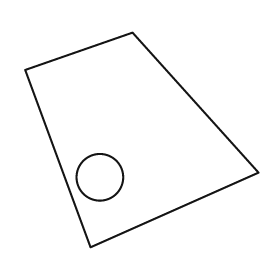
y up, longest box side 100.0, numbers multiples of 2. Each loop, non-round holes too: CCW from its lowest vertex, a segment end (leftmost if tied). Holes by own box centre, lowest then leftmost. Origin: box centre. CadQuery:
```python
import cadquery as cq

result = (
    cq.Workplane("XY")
    .moveTo(-22.0, -46.0)
    .lineTo(50.0, -14.0)
    .lineTo(-4.0, 46.0)
    .lineTo(-50.0, 30.0)
    .close()
    .moveTo(-18.0, -16.0)
    .circle(10.0)
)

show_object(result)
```